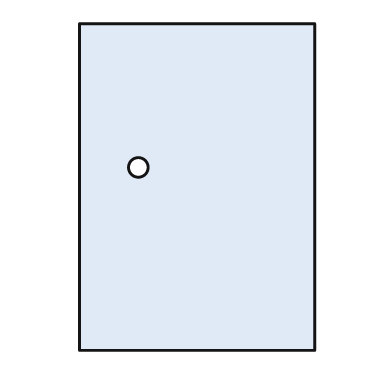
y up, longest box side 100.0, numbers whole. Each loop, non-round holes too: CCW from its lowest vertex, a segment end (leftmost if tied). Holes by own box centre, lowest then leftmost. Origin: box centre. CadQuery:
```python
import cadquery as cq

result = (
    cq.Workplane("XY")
    .moveTo(-36.0, -50.0)
    .lineTo(36.0, -50.0)
    .lineTo(36.0, 50.0)
    .lineTo(-36.0, 50.0)
    .close()
    .moveTo(-18.0, 6.0)
    .circle(3.0)
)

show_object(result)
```